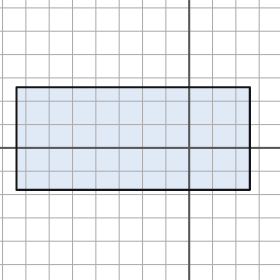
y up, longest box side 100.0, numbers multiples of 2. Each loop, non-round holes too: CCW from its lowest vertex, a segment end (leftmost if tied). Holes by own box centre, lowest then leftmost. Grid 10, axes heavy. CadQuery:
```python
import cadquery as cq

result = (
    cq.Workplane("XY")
    .moveTo(-74.0, -18.0)
    .lineTo(26.0, -18.0)
    .lineTo(26.0, 26.0)
    .lineTo(-74.0, 26.0)
    .close()
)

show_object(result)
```